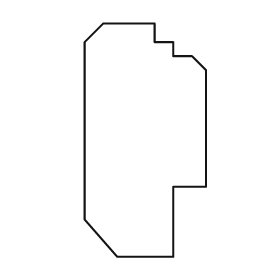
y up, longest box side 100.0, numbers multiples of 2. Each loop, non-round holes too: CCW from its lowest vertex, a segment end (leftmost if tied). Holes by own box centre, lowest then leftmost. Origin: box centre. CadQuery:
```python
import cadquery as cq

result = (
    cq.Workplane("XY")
    .moveTo(-12.0, -50.0)
    .lineTo(12.0, -50.0)
    .lineTo(12.0, -20.0)
    .lineTo(26.0, -20.0)
    .lineTo(26.0, 30.0)
    .lineTo(20.0, 36.0)
    .lineTo(12.0, 36.0)
    .lineTo(12.0, 42.0)
    .lineTo(4.0, 42.0)
    .lineTo(4.0, 50.0)
    .lineTo(-18.0, 50.0)
    .lineTo(-26.0, 42.0)
    .lineTo(-26.0, -34.0)
    .close()
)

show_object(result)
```